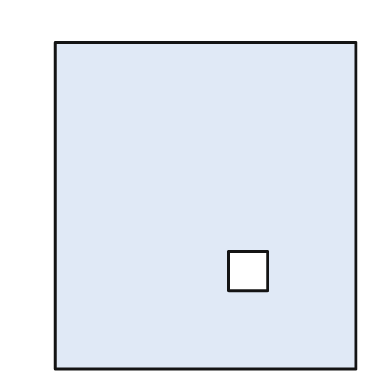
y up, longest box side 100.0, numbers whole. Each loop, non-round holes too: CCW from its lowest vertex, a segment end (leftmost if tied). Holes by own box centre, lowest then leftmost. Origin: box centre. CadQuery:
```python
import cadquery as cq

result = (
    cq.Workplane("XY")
    .moveTo(-46.0, -50.0)
    .lineTo(46.0, -50.0)
    .lineTo(46.0, 50.0)
    .lineTo(-46.0, 50.0)
    .close()
    .moveTo(7.0, -26.0)
    .lineTo(19.0, -26.0)
    .lineTo(19.0, -14.0)
    .lineTo(7.0, -14.0)
    .close()
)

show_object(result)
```